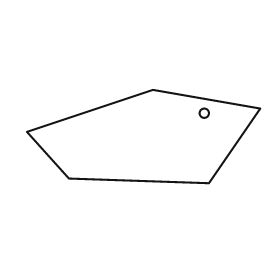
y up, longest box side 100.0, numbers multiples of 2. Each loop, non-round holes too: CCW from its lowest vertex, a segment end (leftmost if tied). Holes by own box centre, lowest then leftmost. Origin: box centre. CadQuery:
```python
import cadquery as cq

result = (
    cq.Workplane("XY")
    .moveTo(28.0, -20.0)
    .lineTo(50.0, 12.0)
    .lineTo(4.0, 20.0)
    .lineTo(-50.0, 2.0)
    .lineTo(-32.0, -18.0)
    .close()
    .moveTo(26.0, 10.0)
    .circle(2.0)
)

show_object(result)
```